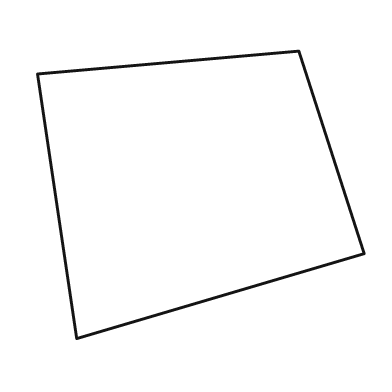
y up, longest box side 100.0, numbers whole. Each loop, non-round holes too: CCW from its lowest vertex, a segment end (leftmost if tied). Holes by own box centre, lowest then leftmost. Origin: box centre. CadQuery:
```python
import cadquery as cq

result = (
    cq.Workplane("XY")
    .moveTo(-38.0, -44.0)
    .lineTo(50.0, -18.0)
    .lineTo(30.0, 44.0)
    .lineTo(-50.0, 37.0)
    .close()
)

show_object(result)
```